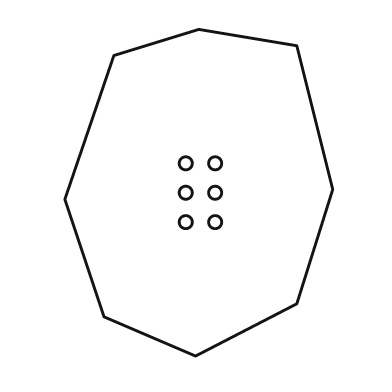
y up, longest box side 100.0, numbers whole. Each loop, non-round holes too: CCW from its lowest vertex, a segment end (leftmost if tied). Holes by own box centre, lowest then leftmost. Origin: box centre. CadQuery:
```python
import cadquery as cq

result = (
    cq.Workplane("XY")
    .moveTo(-1.0, -50.0)
    .lineTo(30.0, -34.0)
    .lineTo(41.0, 1.0)
    .lineTo(30.0, 45.0)
    .lineTo(0.0, 50.0)
    .lineTo(-26.0, 42.0)
    .lineTo(-41.0, -2.0)
    .lineTo(-29.0, -38.0)
    .close()
    .moveTo(-4.0, -9.0)
    .circle(2.0)
    .moveTo(5.0, -9.0)
    .circle(2.0)
    .moveTo(-4.0, 0.0)
    .circle(2.0)
    .moveTo(5.0, 0.0)
    .circle(2.0)
    .moveTo(-4.0, 9.0)
    .circle(2.0)
    .moveTo(5.0, 9.0)
    .circle(2.0)
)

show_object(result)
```